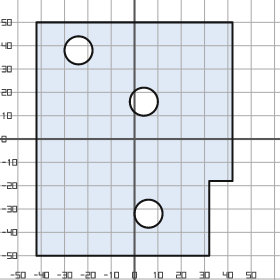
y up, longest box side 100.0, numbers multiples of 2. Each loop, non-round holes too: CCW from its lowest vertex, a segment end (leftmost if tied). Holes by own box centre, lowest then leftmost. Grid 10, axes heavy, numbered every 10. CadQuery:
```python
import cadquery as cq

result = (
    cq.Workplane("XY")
    .moveTo(-42.0, -50.0)
    .lineTo(32.0, -50.0)
    .lineTo(32.0, -18.0)
    .lineTo(42.0, -18.0)
    .lineTo(42.0, 50.0)
    .lineTo(-42.0, 50.0)
    .close()
    .moveTo(6.0, -32.0)
    .circle(6.0)
    .moveTo(4.0, 16.0)
    .circle(6.0)
    .moveTo(-24.0, 38.0)
    .circle(6.0)
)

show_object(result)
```